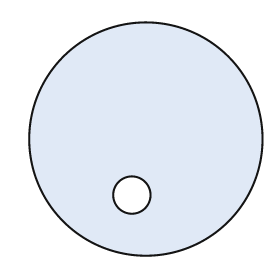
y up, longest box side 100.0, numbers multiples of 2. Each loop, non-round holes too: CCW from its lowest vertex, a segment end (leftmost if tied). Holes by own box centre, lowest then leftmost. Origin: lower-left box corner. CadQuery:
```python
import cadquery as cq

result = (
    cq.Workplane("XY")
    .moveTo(50.0, 50.0)
    .circle(50.0)
    .moveTo(44.0, 26.0)
    .circle(8.0)
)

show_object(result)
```